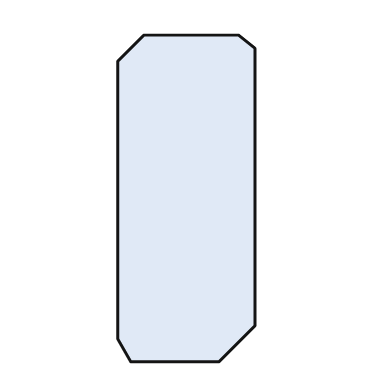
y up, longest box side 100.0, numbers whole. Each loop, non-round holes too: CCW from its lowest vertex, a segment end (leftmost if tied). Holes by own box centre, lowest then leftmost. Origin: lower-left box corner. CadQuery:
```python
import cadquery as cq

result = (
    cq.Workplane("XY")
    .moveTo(4.0, 0.0)
    .lineTo(31.0, 0.0)
    .lineTo(42.0, 11.0)
    .lineTo(42.0, 96.0)
    .lineTo(37.0, 100.0)
    .lineTo(8.0, 100.0)
    .lineTo(0.0, 92.0)
    .lineTo(0.0, 7.0)
    .close()
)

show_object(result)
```